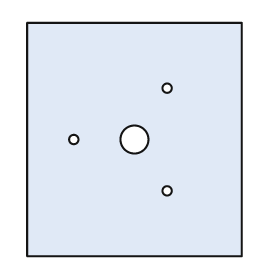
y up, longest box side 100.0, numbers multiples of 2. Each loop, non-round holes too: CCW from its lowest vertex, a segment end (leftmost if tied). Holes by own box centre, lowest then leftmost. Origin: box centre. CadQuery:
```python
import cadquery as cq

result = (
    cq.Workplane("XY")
    .moveTo(-46.0, -50.0)
    .lineTo(46.0, -50.0)
    .lineTo(46.0, 50.0)
    .lineTo(-46.0, 50.0)
    .close()
    .moveTo(14.0, -22.0)
    .circle(2.0)
    .moveTo(-26.0, 0.0)
    .circle(2.0)
    .moveTo(0.0, 0.0)
    .circle(6.0)
    .moveTo(14.0, 22.0)
    .circle(2.0)
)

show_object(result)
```